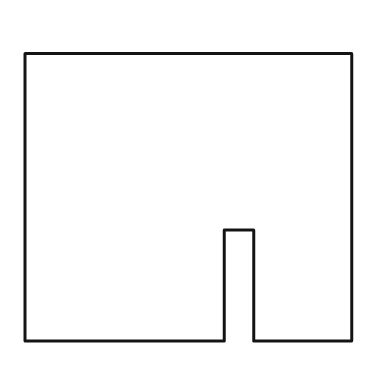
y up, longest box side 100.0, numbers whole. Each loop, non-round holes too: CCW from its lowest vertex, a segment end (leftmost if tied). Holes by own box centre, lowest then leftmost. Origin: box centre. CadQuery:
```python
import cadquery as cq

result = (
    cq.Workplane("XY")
    .moveTo(-50.0, -44.0)
    .lineTo(11.0, -44.0)
    .lineTo(11.0, -10.0)
    .lineTo(20.0, -10.0)
    .lineTo(20.0, -44.0)
    .lineTo(50.0, -44.0)
    .lineTo(50.0, 44.0)
    .lineTo(-50.0, 44.0)
    .close()
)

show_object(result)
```